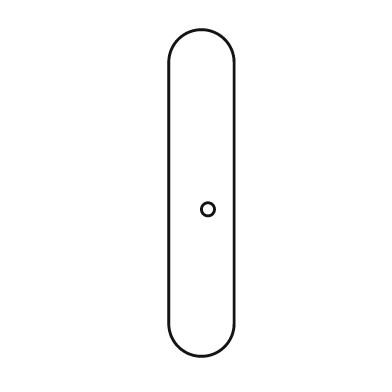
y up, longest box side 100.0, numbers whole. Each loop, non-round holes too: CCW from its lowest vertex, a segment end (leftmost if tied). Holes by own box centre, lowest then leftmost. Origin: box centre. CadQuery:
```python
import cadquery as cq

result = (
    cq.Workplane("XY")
    .moveTo(-10.0, -40.0)
    .threePointArc((0.0, -50.0), (10.0, -40.0))
    .lineTo(10.0, 40.0)
    .threePointArc((0.0, 50.0), (-10.0, 40.0))
    .close()
    .moveTo(2.0, -5.0)
    .circle(2.0)
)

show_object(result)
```